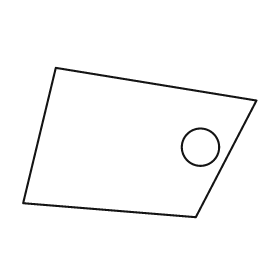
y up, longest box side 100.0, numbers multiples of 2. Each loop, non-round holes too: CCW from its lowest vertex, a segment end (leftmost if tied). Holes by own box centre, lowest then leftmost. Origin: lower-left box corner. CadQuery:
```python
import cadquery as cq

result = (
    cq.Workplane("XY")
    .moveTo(74.0, 0.0)
    .lineTo(100.0, 50.0)
    .lineTo(14.0, 64.0)
    .lineTo(0.0, 6.0)
    .close()
    .moveTo(76.0, 30.0)
    .circle(8.0)
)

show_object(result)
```